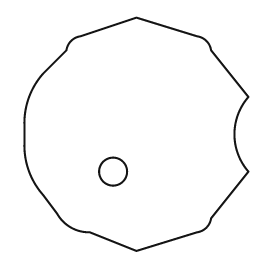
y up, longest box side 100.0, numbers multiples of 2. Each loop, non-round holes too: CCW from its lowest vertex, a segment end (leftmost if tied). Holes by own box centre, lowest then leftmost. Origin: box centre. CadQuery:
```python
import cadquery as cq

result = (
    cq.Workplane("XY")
    .moveTo(0.0, -50.0)
    .lineTo(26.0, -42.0)
    .threePointArc((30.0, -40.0), (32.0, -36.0))
    .lineTo(48.0, -16.0)
    .threePointArc((42.0, 0.0), (48.0, 16.0))
    .lineTo(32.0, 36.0)
    .threePointArc((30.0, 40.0), (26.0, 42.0))
    .lineTo(0.0, 50.0)
    .lineTo(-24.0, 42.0)
    .threePointArc((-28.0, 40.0), (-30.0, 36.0))
    .lineTo(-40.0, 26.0)
    .threePointArc((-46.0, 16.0), (-48.0, 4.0))
    .lineTo(-48.0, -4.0)
    .threePointArc((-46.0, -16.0), (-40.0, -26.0))
    .lineTo(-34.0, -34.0)
    .threePointArc((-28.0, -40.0), (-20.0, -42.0))
    .close()
    .moveTo(-10.0, -16.0)
    .circle(6.0)
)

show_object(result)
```